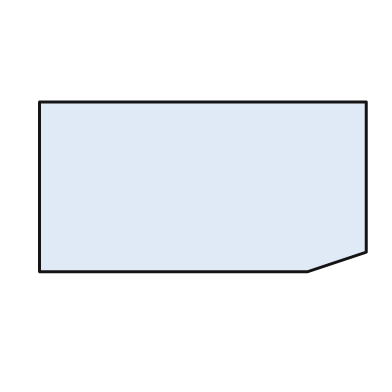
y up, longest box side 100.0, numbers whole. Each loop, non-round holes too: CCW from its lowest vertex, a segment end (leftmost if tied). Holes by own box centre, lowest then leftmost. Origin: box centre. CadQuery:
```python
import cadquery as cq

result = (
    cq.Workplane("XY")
    .moveTo(-50.0, -26.0)
    .lineTo(32.0, -26.0)
    .lineTo(50.0, -20.0)
    .lineTo(50.0, 26.0)
    .lineTo(-50.0, 26.0)
    .close()
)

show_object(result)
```